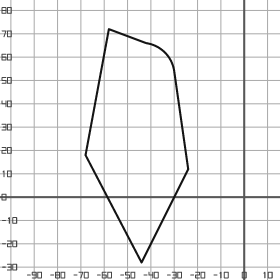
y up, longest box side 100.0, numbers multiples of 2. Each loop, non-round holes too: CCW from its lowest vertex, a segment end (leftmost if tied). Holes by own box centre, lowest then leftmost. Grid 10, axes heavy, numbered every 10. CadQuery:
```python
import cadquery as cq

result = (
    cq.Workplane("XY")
    .moveTo(-44.0, -28.0)
    .lineTo(-24.0, 12.0)
    .lineTo(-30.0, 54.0)
    .threePointArc((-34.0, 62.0), (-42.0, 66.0))
    .lineTo(-58.0, 72.0)
    .lineTo(-68.0, 18.0)
    .close()
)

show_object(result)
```